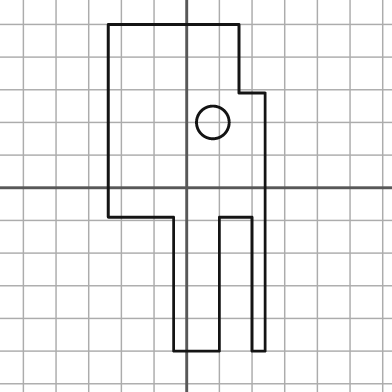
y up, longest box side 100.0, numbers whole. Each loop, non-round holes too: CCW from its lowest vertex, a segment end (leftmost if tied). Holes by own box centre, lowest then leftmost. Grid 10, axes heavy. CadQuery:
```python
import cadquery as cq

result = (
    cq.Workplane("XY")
    .moveTo(-4.0, -50.0)
    .lineTo(10.0, -50.0)
    .lineTo(10.0, -9.0)
    .lineTo(20.0, -9.0)
    .lineTo(20.0, -50.0)
    .lineTo(24.0, -50.0)
    .lineTo(24.0, 29.0)
    .lineTo(16.0, 29.0)
    .lineTo(16.0, 50.0)
    .lineTo(-24.0, 50.0)
    .lineTo(-24.0, -9.0)
    .lineTo(-4.0, -9.0)
    .close()
    .moveTo(8.0, 20.0)
    .circle(5.0)
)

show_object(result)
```